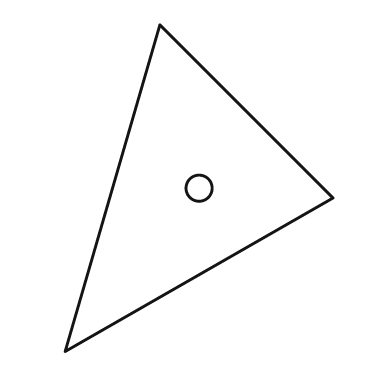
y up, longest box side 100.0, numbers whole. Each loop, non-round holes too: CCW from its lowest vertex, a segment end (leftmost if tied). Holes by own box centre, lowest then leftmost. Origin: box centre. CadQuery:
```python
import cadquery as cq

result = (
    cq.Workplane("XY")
    .moveTo(-41.0, -50.0)
    .lineTo(41.0, -3.0)
    .lineTo(-12.0, 50.0)
    .close()
    .moveTo(0.0, 0.0)
    .circle(4.0)
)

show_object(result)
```